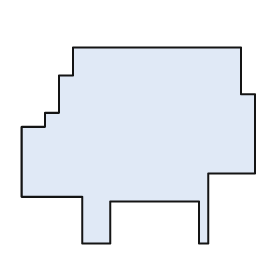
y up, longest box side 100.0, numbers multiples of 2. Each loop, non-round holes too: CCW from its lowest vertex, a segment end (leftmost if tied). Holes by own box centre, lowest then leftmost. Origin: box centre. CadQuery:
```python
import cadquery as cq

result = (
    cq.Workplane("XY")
    .moveTo(-24.0, -42.0)
    .lineTo(-12.0, -42.0)
    .lineTo(-12.0, -24.0)
    .lineTo(26.0, -24.0)
    .lineTo(26.0, -42.0)
    .lineTo(30.0, -42.0)
    .lineTo(30.0, -12.0)
    .lineTo(50.0, -12.0)
    .lineTo(50.0, 22.0)
    .lineTo(44.0, 22.0)
    .lineTo(44.0, 42.0)
    .lineTo(-28.0, 42.0)
    .lineTo(-28.0, 30.0)
    .lineTo(-34.0, 30.0)
    .lineTo(-34.0, 14.0)
    .lineTo(-40.0, 14.0)
    .lineTo(-40.0, 8.0)
    .lineTo(-50.0, 8.0)
    .lineTo(-50.0, -22.0)
    .lineTo(-24.0, -22.0)
    .close()
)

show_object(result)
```